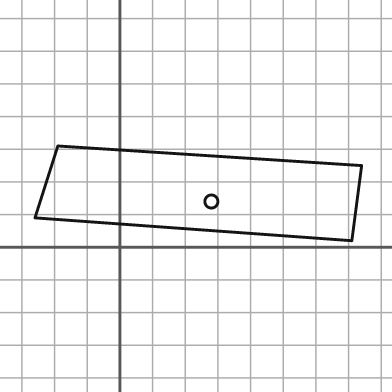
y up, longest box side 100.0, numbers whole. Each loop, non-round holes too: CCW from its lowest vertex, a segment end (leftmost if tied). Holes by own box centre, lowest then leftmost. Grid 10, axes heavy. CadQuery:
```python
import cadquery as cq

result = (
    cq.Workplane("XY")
    .moveTo(71.0, 2.0)
    .lineTo(74.0, 25.0)
    .lineTo(-19.0, 31.0)
    .lineTo(-26.0, 9.0)
    .close()
    .moveTo(28.0, 14.0)
    .circle(2.0)
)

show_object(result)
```